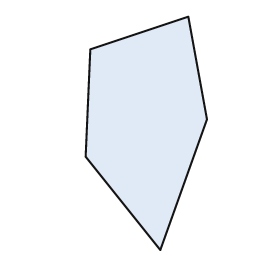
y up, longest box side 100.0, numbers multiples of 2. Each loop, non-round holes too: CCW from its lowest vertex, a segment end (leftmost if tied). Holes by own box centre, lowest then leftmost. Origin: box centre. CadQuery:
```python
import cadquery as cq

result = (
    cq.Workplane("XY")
    .moveTo(6.0, -50.0)
    .lineTo(26.0, 6.0)
    .lineTo(18.0, 50.0)
    .lineTo(-24.0, 36.0)
    .lineTo(-26.0, -10.0)
    .close()
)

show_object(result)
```